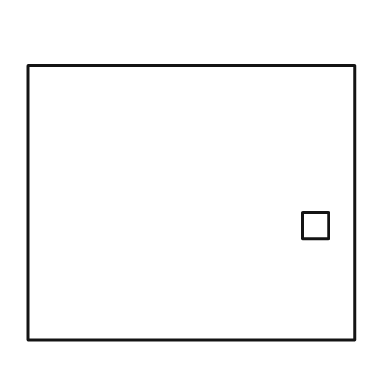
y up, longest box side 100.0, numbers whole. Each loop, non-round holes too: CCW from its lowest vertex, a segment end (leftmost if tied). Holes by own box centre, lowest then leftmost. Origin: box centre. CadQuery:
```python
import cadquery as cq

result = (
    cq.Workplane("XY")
    .moveTo(-50.0, -42.0)
    .lineTo(50.0, -42.0)
    .lineTo(50.0, 42.0)
    .lineTo(-50.0, 42.0)
    .close()
    .moveTo(34.0, -11.0)
    .lineTo(42.0, -11.0)
    .lineTo(42.0, -3.0)
    .lineTo(34.0, -3.0)
    .close()
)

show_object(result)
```